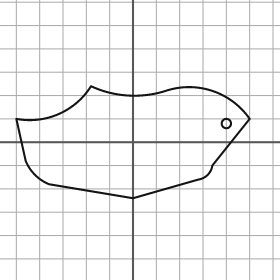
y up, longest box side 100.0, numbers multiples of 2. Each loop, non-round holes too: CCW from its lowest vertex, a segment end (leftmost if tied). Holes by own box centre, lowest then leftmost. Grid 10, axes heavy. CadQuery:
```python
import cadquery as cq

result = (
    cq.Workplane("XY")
    .moveTo(0.0, -24.0)
    .lineTo(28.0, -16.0)
    .threePointArc((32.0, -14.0), (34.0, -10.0))
    .lineTo(50.0, 10.0)
    .threePointArc((34.0, 22.0), (14.0, 22.0))
    .threePointArc((-2.0, 20.0), (-18.0, 24.0))
    .threePointArc((-32.0, 12.0), (-50.0, 10.0))
    .lineTo(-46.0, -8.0)
    .threePointArc((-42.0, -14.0), (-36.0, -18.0))
    .close()
    .moveTo(40.0, 8.0)
    .circle(2.0)
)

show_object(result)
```